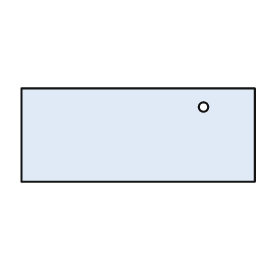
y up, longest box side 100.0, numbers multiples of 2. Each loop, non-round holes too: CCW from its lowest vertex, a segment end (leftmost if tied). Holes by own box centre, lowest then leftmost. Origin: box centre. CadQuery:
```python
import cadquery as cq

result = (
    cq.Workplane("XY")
    .moveTo(-50.0, -20.0)
    .lineTo(50.0, -20.0)
    .lineTo(50.0, 20.0)
    .lineTo(-50.0, 20.0)
    .close()
    .moveTo(28.0, 12.0)
    .circle(2.0)
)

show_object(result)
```